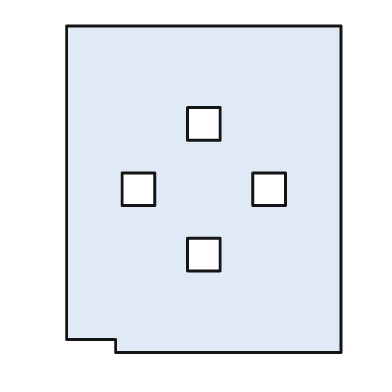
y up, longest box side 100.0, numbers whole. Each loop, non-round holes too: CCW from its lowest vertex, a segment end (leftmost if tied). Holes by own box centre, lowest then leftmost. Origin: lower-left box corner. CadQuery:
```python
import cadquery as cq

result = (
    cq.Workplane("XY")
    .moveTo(15.0, 0.0)
    .lineTo(84.0, 0.0)
    .lineTo(84.0, 100.0)
    .lineTo(0.0, 100.0)
    .lineTo(0.0, 4.0)
    .lineTo(15.0, 4.0)
    .close()
    .moveTo(37.0, 25.0)
    .lineTo(47.0, 25.0)
    .lineTo(47.0, 35.0)
    .lineTo(37.0, 35.0)
    .close()
    .moveTo(17.0, 45.0)
    .lineTo(27.0, 45.0)
    .lineTo(27.0, 55.0)
    .lineTo(17.0, 55.0)
    .close()
    .moveTo(57.0, 45.0)
    .lineTo(67.0, 45.0)
    .lineTo(67.0, 55.0)
    .lineTo(57.0, 55.0)
    .close()
    .moveTo(37.0, 65.0)
    .lineTo(47.0, 65.0)
    .lineTo(47.0, 75.0)
    .lineTo(37.0, 75.0)
    .close()
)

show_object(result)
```